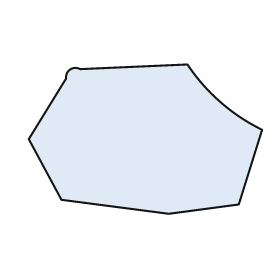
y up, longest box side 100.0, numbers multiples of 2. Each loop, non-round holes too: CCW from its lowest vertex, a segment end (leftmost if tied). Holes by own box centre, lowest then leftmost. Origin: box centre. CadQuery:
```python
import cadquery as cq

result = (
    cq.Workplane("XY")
    .moveTo(10.0, -32.0)
    .lineTo(40.0, -28.0)
    .lineTo(50.0, 4.0)
    .threePointArc((32.0, 16.0), (18.0, 32.0))
    .lineTo(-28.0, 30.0)
    .threePointArc((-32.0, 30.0), (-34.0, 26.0))
    .lineTo(-50.0, 0.0)
    .lineTo(-36.0, -26.0)
    .close()
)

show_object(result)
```